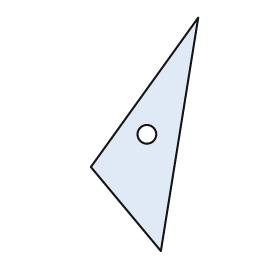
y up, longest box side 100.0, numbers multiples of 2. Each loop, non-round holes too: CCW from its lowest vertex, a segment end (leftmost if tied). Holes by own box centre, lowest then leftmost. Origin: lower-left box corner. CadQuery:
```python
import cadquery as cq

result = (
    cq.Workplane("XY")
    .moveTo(30.0, 0.0)
    .lineTo(46.0, 100.0)
    .lineTo(0.0, 36.0)
    .close()
    .moveTo(24.0, 50.0)
    .circle(4.0)
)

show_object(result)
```